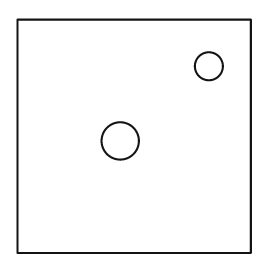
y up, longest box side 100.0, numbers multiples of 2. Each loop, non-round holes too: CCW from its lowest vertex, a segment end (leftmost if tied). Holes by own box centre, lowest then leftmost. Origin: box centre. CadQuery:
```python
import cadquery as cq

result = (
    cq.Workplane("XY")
    .moveTo(-50.0, -50.0)
    .lineTo(50.0, -50.0)
    .lineTo(50.0, 50.0)
    .lineTo(-50.0, 50.0)
    .close()
    .moveTo(-6.0, -2.0)
    .circle(8.0)
    .moveTo(32.0, 30.0)
    .circle(6.0)
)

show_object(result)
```